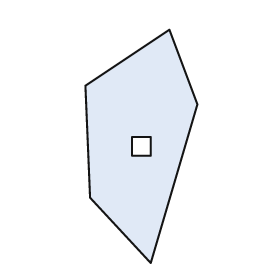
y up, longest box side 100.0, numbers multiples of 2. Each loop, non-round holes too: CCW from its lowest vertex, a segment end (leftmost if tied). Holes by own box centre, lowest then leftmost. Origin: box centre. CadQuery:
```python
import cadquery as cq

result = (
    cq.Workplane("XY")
    .moveTo(4.0, -50.0)
    .lineTo(24.0, 18.0)
    .lineTo(12.0, 50.0)
    .lineTo(-24.0, 26.0)
    .lineTo(-22.0, -22.0)
    .close()
    .moveTo(-4.0, -4.0)
    .lineTo(4.0, -4.0)
    .lineTo(4.0, 4.0)
    .lineTo(-4.0, 4.0)
    .close()
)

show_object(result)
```